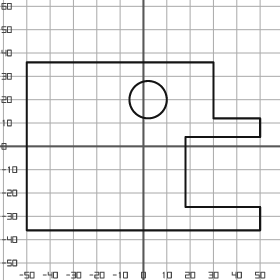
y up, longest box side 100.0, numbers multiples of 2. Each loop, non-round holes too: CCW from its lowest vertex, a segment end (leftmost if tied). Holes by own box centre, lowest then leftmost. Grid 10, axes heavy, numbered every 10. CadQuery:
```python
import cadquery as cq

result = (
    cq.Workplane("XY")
    .moveTo(-50.0, -36.0)
    .lineTo(50.0, -36.0)
    .lineTo(50.0, -26.0)
    .lineTo(18.0, -26.0)
    .lineTo(18.0, 4.0)
    .lineTo(50.0, 4.0)
    .lineTo(50.0, 12.0)
    .lineTo(30.0, 12.0)
    .lineTo(30.0, 36.0)
    .lineTo(-50.0, 36.0)
    .close()
    .moveTo(2.0, 20.0)
    .circle(8.0)
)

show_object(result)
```